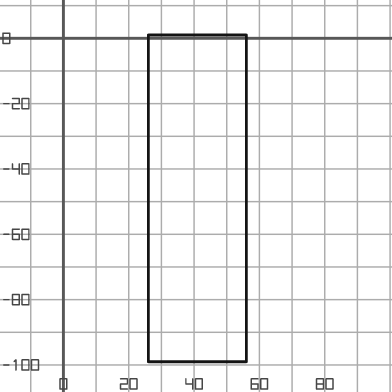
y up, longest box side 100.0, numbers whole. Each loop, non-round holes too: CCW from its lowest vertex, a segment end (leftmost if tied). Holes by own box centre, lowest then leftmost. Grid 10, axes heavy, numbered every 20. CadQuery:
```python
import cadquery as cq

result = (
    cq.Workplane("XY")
    .moveTo(26.0, -99.0)
    .lineTo(56.0, -99.0)
    .lineTo(56.0, 1.0)
    .lineTo(26.0, 1.0)
    .close()
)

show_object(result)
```